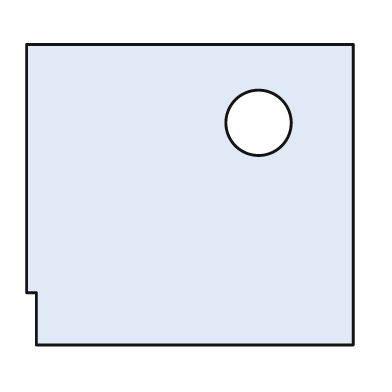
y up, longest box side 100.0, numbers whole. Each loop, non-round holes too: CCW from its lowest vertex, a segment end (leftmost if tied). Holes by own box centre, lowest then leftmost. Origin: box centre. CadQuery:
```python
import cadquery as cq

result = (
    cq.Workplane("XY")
    .moveTo(-47.0, -46.0)
    .lineTo(50.0, -46.0)
    .lineTo(50.0, 46.0)
    .lineTo(-50.0, 46.0)
    .lineTo(-50.0, -30.0)
    .lineTo(-47.0, -30.0)
    .close()
    .moveTo(21.0, 22.0)
    .circle(10.0)
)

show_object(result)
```